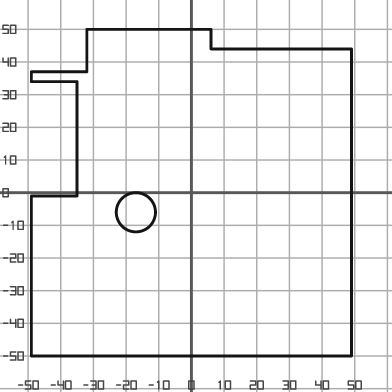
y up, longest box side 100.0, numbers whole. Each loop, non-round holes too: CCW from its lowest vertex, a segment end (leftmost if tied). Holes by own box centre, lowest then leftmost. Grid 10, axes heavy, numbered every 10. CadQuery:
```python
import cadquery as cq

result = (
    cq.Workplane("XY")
    .moveTo(-49.0, -50.0)
    .lineTo(49.0, -50.0)
    .lineTo(49.0, 44.0)
    .lineTo(6.0, 44.0)
    .lineTo(6.0, 50.0)
    .lineTo(-32.0, 50.0)
    .lineTo(-32.0, 37.0)
    .lineTo(-49.0, 37.0)
    .lineTo(-49.0, 34.0)
    .lineTo(-35.0, 34.0)
    .lineTo(-35.0, -1.0)
    .lineTo(-49.0, -1.0)
    .close()
    .moveTo(-17.0, -6.0)
    .circle(6.0)
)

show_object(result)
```